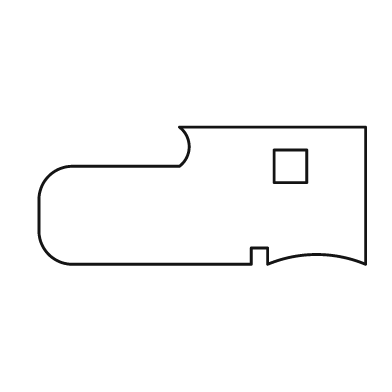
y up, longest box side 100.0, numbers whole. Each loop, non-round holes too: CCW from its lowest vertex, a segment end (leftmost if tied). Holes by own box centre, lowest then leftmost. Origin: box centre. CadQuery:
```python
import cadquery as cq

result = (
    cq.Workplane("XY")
    .moveTo(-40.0, -21.0)
    .lineTo(15.0, -21.0)
    .lineTo(15.0, -16.0)
    .lineTo(20.0, -16.0)
    .lineTo(20.0, -21.0)
    .threePointArc((35.0, -18.0), (50.0, -21.0))
    .lineTo(50.0, 21.0)
    .lineTo(-7.0, 21.0)
    .threePointArc((-4.0, 15.0), (-7.0, 9.0))
    .lineTo(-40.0, 9.0)
    .threePointArc((-47.0, 6.0), (-50.0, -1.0))
    .lineTo(-50.0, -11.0)
    .threePointArc((-47.0, -18.0), (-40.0, -21.0))
    .close()
    .moveTo(22.0, 4.0)
    .lineTo(32.0, 4.0)
    .lineTo(32.0, 14.0)
    .lineTo(22.0, 14.0)
    .close()
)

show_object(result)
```